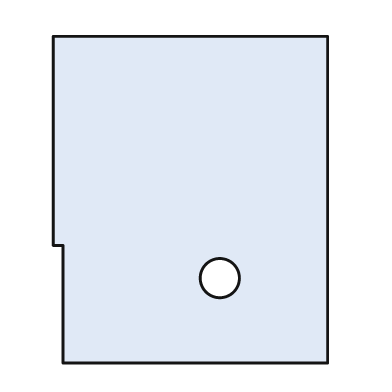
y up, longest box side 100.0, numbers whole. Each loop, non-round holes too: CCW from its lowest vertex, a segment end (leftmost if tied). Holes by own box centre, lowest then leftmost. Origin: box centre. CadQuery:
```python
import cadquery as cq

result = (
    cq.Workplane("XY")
    .moveTo(-39.0, -50.0)
    .lineTo(42.0, -50.0)
    .lineTo(42.0, 50.0)
    .lineTo(-42.0, 50.0)
    .lineTo(-42.0, -14.0)
    .lineTo(-39.0, -14.0)
    .close()
    .moveTo(9.0, -24.0)
    .circle(6.0)
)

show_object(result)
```